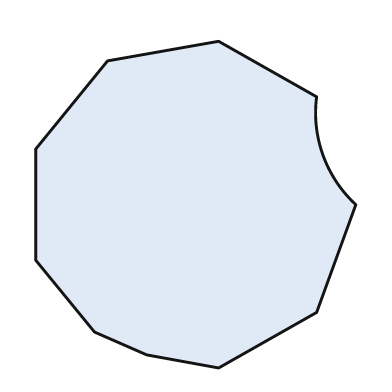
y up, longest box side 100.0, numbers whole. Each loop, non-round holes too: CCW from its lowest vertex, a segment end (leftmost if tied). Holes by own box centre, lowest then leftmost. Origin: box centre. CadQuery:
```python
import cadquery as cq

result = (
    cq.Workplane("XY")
    .moveTo(7.0, -50.0)
    .lineTo(37.0, -33.0)
    .lineTo(49.0, 0.0)
    .threePointArc((39.0, 15.0), (37.0, 33.0))
    .lineTo(7.0, 50.0)
    .lineTo(-27.0, 44.0)
    .lineTo(-49.0, 17.0)
    .lineTo(-49.0, -17.0)
    .lineTo(-31.0, -39.0)
    .lineTo(-15.0, -46.0)
    .close()
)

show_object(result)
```